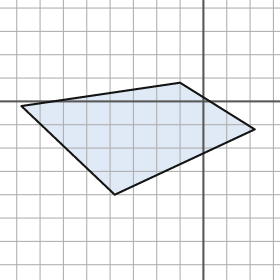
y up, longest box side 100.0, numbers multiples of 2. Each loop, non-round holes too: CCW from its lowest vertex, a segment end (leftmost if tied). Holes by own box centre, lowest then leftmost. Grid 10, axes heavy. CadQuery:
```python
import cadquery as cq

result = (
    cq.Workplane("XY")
    .moveTo(-38.0, -40.0)
    .lineTo(22.0, -12.0)
    .lineTo(-10.0, 8.0)
    .lineTo(-78.0, -2.0)
    .close()
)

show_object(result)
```